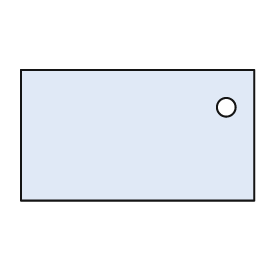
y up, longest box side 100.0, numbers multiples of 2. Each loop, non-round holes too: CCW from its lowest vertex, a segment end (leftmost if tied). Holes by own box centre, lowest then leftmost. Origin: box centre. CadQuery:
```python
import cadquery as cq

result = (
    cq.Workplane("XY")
    .moveTo(-50.0, -28.0)
    .lineTo(50.0, -28.0)
    .lineTo(50.0, 28.0)
    .lineTo(-50.0, 28.0)
    .close()
    .moveTo(38.0, 12.0)
    .circle(4.0)
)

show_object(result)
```